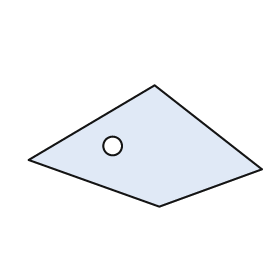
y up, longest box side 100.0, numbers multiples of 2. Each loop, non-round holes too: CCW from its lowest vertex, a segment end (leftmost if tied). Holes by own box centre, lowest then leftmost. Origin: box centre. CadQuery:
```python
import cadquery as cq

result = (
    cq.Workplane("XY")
    .moveTo(6.0, -26.0)
    .lineTo(50.0, -10.0)
    .lineTo(4.0, 26.0)
    .lineTo(-50.0, -6.0)
    .close()
    .moveTo(-14.0, 0.0)
    .circle(4.0)
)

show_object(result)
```